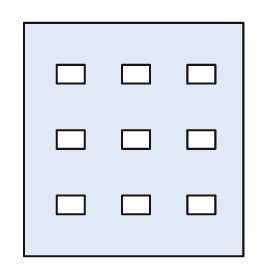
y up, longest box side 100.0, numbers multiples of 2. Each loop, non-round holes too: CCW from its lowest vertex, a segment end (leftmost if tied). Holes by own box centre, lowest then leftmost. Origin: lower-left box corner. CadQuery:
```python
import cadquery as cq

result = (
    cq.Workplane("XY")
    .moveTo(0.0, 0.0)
    .lineTo(94.0, 0.0)
    .lineTo(94.0, 100.0)
    .lineTo(0.0, 100.0)
    .close()
    .moveTo(14.0, 18.0)
    .lineTo(26.0, 18.0)
    .lineTo(26.0, 26.0)
    .lineTo(14.0, 26.0)
    .close()
    .moveTo(42.0, 18.0)
    .lineTo(54.0, 18.0)
    .lineTo(54.0, 26.0)
    .lineTo(42.0, 26.0)
    .close()
    .moveTo(70.0, 18.0)
    .lineTo(82.0, 18.0)
    .lineTo(82.0, 26.0)
    .lineTo(70.0, 26.0)
    .close()
    .moveTo(14.0, 46.0)
    .lineTo(26.0, 46.0)
    .lineTo(26.0, 54.0)
    .lineTo(14.0, 54.0)
    .close()
    .moveTo(42.0, 46.0)
    .lineTo(54.0, 46.0)
    .lineTo(54.0, 54.0)
    .lineTo(42.0, 54.0)
    .close()
    .moveTo(70.0, 46.0)
    .lineTo(82.0, 46.0)
    .lineTo(82.0, 54.0)
    .lineTo(70.0, 54.0)
    .close()
    .moveTo(14.0, 74.0)
    .lineTo(26.0, 74.0)
    .lineTo(26.0, 82.0)
    .lineTo(14.0, 82.0)
    .close()
    .moveTo(42.0, 74.0)
    .lineTo(54.0, 74.0)
    .lineTo(54.0, 82.0)
    .lineTo(42.0, 82.0)
    .close()
    .moveTo(70.0, 74.0)
    .lineTo(82.0, 74.0)
    .lineTo(82.0, 82.0)
    .lineTo(70.0, 82.0)
    .close()
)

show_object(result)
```